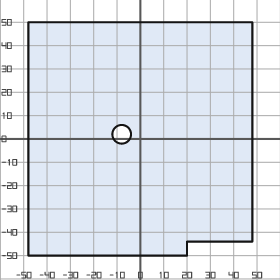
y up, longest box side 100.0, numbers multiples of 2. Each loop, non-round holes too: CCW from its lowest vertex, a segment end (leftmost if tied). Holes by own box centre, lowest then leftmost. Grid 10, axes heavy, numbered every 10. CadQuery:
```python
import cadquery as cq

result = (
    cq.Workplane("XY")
    .moveTo(-48.0, -50.0)
    .lineTo(20.0, -50.0)
    .lineTo(20.0, -44.0)
    .lineTo(48.0, -44.0)
    .lineTo(48.0, 50.0)
    .lineTo(-48.0, 50.0)
    .close()
    .moveTo(-8.0, 2.0)
    .circle(4.0)
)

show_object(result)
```